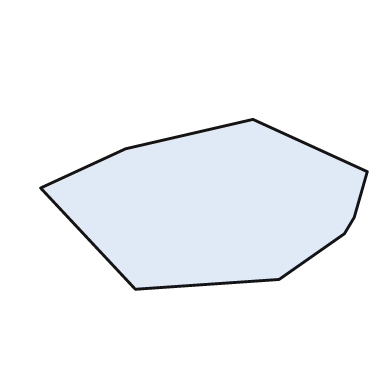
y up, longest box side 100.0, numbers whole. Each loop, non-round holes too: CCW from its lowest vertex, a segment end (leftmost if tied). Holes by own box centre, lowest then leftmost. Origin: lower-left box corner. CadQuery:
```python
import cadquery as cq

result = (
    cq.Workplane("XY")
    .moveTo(29.0, 0.0)
    .lineTo(73.0, 3.0)
    .lineTo(93.0, 17.0)
    .lineTo(96.0, 22.0)
    .lineTo(100.0, 36.0)
    .lineTo(65.0, 52.0)
    .lineTo(26.0, 43.0)
    .lineTo(0.0, 31.0)
    .close()
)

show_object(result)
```